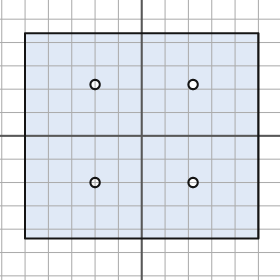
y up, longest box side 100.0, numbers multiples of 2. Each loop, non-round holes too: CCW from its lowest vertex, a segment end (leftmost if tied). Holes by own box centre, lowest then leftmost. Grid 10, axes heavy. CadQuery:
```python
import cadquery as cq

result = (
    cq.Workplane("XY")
    .moveTo(-50.0, -44.0)
    .lineTo(50.0, -44.0)
    .lineTo(50.0, 44.0)
    .lineTo(-50.0, 44.0)
    .close()
    .moveTo(-20.0, -20.0)
    .circle(2.0)
    .moveTo(22.0, -20.0)
    .circle(2.0)
    .moveTo(-20.0, 22.0)
    .circle(2.0)
    .moveTo(22.0, 22.0)
    .circle(2.0)
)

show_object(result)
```